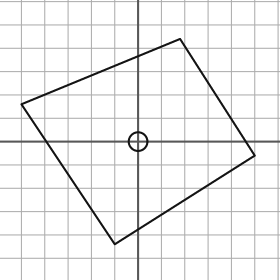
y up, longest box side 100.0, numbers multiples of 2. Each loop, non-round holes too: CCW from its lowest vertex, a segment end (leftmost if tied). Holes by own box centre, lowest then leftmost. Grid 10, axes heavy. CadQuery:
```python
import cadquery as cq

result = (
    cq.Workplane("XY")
    .moveTo(-10.0, -44.0)
    .lineTo(50.0, -6.0)
    .lineTo(18.0, 44.0)
    .lineTo(-50.0, 16.0)
    .close()
    .moveTo(0.0, 0.0)
    .circle(4.0)
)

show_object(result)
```